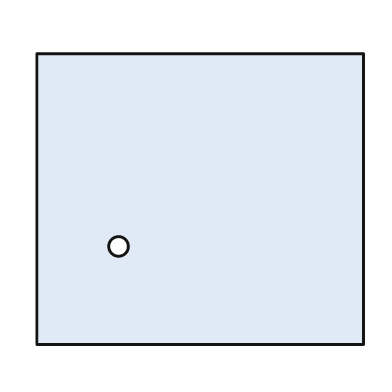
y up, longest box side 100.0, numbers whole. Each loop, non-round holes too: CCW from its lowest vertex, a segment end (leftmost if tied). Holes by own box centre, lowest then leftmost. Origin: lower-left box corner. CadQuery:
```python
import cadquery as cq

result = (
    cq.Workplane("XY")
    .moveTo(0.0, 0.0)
    .lineTo(100.0, 0.0)
    .lineTo(100.0, 89.0)
    .lineTo(0.0, 89.0)
    .close()
    .moveTo(25.0, 30.0)
    .circle(3.0)
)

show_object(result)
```